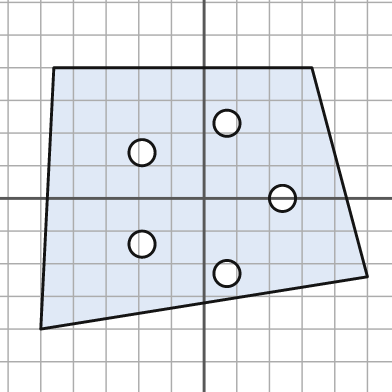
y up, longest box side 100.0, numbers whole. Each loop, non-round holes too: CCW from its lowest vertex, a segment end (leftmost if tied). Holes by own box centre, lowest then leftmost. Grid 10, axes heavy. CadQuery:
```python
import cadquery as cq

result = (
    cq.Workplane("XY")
    .moveTo(-50.0, -40.0)
    .lineTo(50.0, -24.0)
    .lineTo(33.0, 40.0)
    .lineTo(-46.0, 40.0)
    .close()
    .moveTo(7.0, -23.0)
    .circle(4.0)
    .moveTo(-19.0, -14.0)
    .circle(4.0)
    .moveTo(24.0, 0.0)
    .circle(4.0)
    .moveTo(-19.0, 14.0)
    .circle(4.0)
    .moveTo(7.0, 23.0)
    .circle(4.0)
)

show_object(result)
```